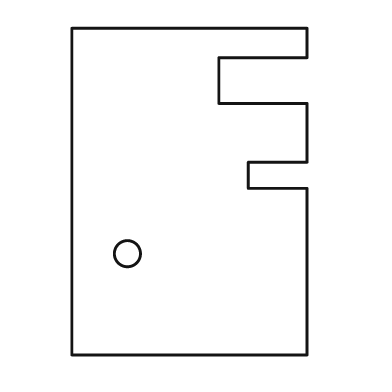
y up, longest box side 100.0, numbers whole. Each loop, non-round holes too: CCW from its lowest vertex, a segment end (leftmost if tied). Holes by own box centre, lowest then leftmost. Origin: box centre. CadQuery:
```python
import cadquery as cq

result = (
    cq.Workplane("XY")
    .moveTo(-36.0, -50.0)
    .lineTo(36.0, -50.0)
    .lineTo(36.0, 1.0)
    .lineTo(18.0, 1.0)
    .lineTo(18.0, 9.0)
    .lineTo(36.0, 9.0)
    .lineTo(36.0, 27.0)
    .lineTo(9.0, 27.0)
    .lineTo(9.0, 41.0)
    .lineTo(36.0, 41.0)
    .lineTo(36.0, 50.0)
    .lineTo(-36.0, 50.0)
    .close()
    .moveTo(-19.0, -19.0)
    .circle(4.0)
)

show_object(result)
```